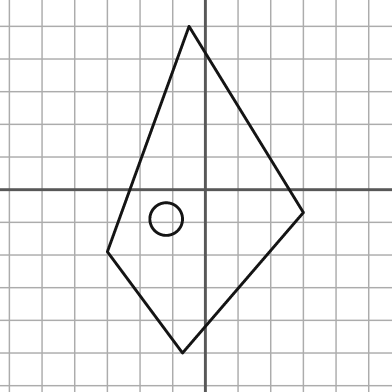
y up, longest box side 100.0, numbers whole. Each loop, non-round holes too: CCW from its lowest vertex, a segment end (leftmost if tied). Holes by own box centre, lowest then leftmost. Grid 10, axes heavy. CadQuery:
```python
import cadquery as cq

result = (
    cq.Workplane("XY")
    .moveTo(-7.0, -50.0)
    .lineTo(30.0, -7.0)
    .lineTo(-5.0, 50.0)
    .lineTo(-30.0, -19.0)
    .close()
    .moveTo(-12.0, -9.0)
    .circle(5.0)
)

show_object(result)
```